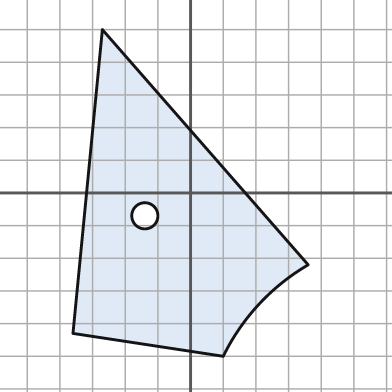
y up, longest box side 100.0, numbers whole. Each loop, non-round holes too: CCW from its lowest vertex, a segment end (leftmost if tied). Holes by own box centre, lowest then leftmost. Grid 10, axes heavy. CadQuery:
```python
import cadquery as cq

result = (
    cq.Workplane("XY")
    .moveTo(10.0, -50.0)
    .threePointArc((21.0, -34.0), (36.0, -22.0))
    .lineTo(-27.0, 50.0)
    .lineTo(-36.0, -43.0)
    .close()
    .moveTo(-14.0, -7.0)
    .circle(4.0)
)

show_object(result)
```